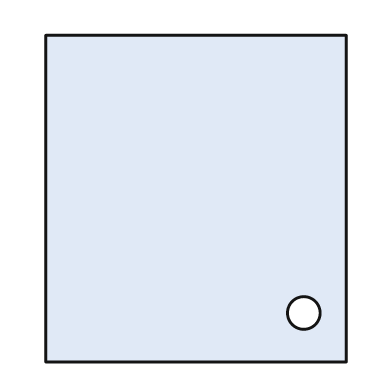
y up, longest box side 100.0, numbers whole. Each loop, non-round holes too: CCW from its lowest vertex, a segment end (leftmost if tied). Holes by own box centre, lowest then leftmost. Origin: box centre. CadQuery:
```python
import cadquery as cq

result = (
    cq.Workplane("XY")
    .moveTo(-46.0, -50.0)
    .lineTo(46.0, -50.0)
    .lineTo(46.0, 50.0)
    .lineTo(-46.0, 50.0)
    .close()
    .moveTo(33.0, -35.0)
    .circle(5.0)
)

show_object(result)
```